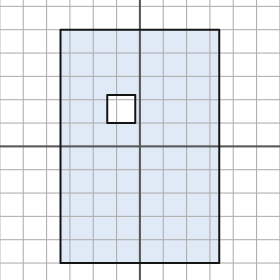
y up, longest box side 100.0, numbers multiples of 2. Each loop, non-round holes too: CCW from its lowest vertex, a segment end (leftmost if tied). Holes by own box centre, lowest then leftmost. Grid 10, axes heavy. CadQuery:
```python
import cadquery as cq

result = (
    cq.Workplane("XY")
    .moveTo(-34.0, -50.0)
    .lineTo(34.0, -50.0)
    .lineTo(34.0, 50.0)
    .lineTo(-34.0, 50.0)
    .close()
    .moveTo(-14.0, 10.0)
    .lineTo(-2.0, 10.0)
    .lineTo(-2.0, 22.0)
    .lineTo(-14.0, 22.0)
    .close()
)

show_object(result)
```